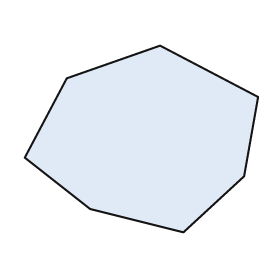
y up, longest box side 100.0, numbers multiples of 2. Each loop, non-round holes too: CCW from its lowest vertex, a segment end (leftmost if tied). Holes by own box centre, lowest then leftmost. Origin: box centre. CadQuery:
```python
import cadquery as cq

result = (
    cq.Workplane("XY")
    .moveTo(18.0, -40.0)
    .lineTo(44.0, -16.0)
    .lineTo(50.0, 18.0)
    .lineTo(8.0, 40.0)
    .lineTo(-32.0, 26.0)
    .lineTo(-50.0, -8.0)
    .lineTo(-22.0, -30.0)
    .close()
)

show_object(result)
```